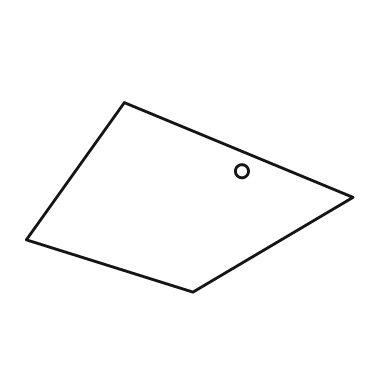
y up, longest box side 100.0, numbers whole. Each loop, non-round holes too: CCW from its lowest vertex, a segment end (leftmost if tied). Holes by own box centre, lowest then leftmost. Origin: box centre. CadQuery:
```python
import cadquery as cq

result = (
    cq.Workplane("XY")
    .moveTo(1.0, -29.0)
    .lineTo(50.0, 0.0)
    .lineTo(-20.0, 29.0)
    .lineTo(-50.0, -13.0)
    .close()
    .moveTo(16.0, 8.0)
    .circle(2.0)
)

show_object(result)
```